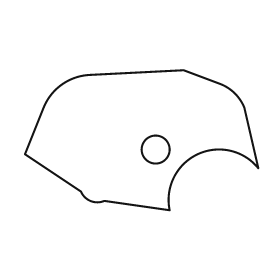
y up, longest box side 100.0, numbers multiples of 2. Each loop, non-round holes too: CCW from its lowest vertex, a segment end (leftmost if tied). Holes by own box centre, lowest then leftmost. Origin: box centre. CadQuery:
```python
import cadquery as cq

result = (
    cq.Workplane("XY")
    .moveTo(12.0, -30.0)
    .threePointArc((24.0, -6.0), (50.0, -12.0))
    .lineTo(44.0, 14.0)
    .threePointArc((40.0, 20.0), (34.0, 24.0))
    .lineTo(18.0, 30.0)
    .lineTo(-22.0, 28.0)
    .threePointArc((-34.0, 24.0), (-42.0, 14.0))
    .lineTo(-50.0, -6.0)
    .lineTo(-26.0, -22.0)
    .threePointArc((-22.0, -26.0), (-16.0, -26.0))
    .close()
    .moveTo(6.0, -4.0)
    .circle(6.0)
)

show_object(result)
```